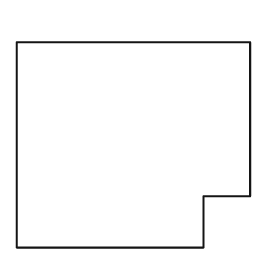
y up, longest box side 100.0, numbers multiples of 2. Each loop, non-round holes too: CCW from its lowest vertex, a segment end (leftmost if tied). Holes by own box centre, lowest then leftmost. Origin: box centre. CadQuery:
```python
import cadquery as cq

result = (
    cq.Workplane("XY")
    .moveTo(-50.0, -44.0)
    .lineTo(30.0, -44.0)
    .lineTo(30.0, -22.0)
    .lineTo(50.0, -22.0)
    .lineTo(50.0, 44.0)
    .lineTo(-50.0, 44.0)
    .close()
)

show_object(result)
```